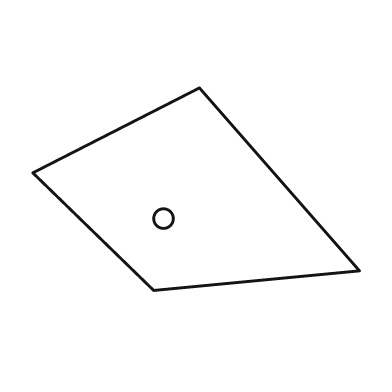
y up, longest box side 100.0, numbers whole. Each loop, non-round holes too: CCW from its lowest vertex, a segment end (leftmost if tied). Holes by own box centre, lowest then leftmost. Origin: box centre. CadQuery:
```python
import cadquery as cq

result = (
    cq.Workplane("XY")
    .moveTo(-13.0, -31.0)
    .lineTo(50.0, -25.0)
    .lineTo(1.0, 31.0)
    .lineTo(-50.0, 5.0)
    .close()
    .moveTo(-10.0, -9.0)
    .circle(3.0)
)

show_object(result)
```